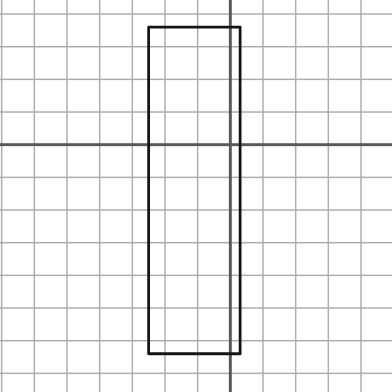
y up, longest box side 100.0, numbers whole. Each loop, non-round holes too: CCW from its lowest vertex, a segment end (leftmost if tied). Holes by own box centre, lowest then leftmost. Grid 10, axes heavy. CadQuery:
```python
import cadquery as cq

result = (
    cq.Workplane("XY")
    .moveTo(-25.0, -64.0)
    .lineTo(3.0, -64.0)
    .lineTo(3.0, 36.0)
    .lineTo(-25.0, 36.0)
    .close()
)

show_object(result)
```